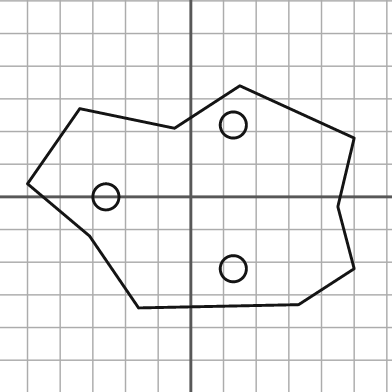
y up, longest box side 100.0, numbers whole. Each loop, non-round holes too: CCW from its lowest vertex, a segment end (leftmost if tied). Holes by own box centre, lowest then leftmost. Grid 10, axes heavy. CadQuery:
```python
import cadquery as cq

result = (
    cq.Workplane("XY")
    .moveTo(-16.0, -34.0)
    .lineTo(33.0, -33.0)
    .lineTo(50.0, -22.0)
    .lineTo(45.0, -3.0)
    .lineTo(50.0, 18.0)
    .lineTo(15.0, 34.0)
    .lineTo(-5.0, 21.0)
    .lineTo(-34.0, 27.0)
    .lineTo(-50.0, 4.0)
    .lineTo(-31.0, -12.0)
    .close()
    .moveTo(13.0, -22.0)
    .circle(4.0)
    .moveTo(-26.0, 0.0)
    .circle(4.0)
    .moveTo(13.0, 22.0)
    .circle(4.0)
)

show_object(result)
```